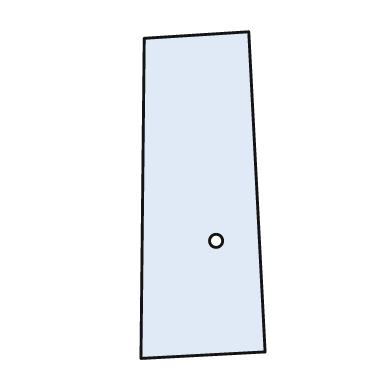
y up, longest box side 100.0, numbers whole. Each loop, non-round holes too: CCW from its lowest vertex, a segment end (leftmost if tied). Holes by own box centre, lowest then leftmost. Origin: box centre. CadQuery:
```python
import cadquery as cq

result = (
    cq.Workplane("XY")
    .moveTo(-19.0, -50.0)
    .lineTo(19.0, -48.0)
    .lineTo(14.0, 50.0)
    .lineTo(-18.0, 48.0)
    .close()
    .moveTo(4.0, -14.0)
    .circle(2.0)
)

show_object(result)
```